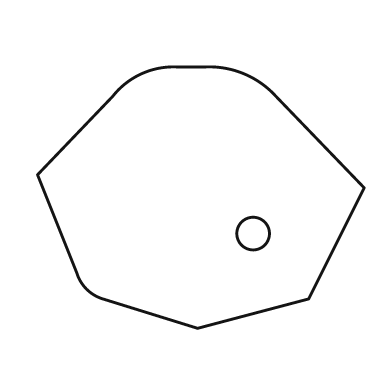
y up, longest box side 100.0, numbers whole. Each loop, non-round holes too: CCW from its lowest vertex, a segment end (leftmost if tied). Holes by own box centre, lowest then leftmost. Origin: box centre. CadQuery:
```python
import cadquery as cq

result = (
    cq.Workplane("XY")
    .moveTo(-1.0, -40.0)
    .lineTo(33.0, -31.0)
    .lineTo(50.0, 3.0)
    .lineTo(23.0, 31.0)
    .threePointArc((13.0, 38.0), (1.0, 40.0))
    .lineTo(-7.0, 40.0)
    .threePointArc((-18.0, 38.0), (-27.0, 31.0))
    .lineTo(-50.0, 7.0)
    .lineTo(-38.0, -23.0)
    .threePointArc((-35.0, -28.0), (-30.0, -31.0))
    .close()
    .moveTo(16.0, -11.0)
    .circle(5.0)
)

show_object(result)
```